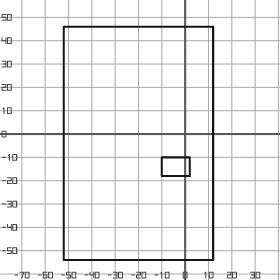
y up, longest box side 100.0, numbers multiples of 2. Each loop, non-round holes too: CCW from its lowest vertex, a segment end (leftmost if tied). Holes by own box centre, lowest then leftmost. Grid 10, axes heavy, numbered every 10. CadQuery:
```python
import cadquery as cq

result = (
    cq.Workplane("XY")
    .moveTo(-52.0, -54.0)
    .lineTo(12.0, -54.0)
    .lineTo(12.0, 46.0)
    .lineTo(-52.0, 46.0)
    .close()
    .moveTo(-10.0, -18.0)
    .lineTo(2.0, -18.0)
    .lineTo(2.0, -10.0)
    .lineTo(-10.0, -10.0)
    .close()
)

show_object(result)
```